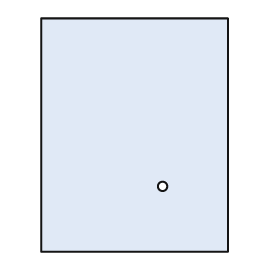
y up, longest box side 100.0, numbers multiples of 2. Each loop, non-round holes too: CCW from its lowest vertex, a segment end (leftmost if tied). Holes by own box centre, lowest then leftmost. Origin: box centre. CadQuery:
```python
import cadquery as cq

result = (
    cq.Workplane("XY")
    .moveTo(-40.0, -50.0)
    .lineTo(40.0, -50.0)
    .lineTo(40.0, 50.0)
    .lineTo(-40.0, 50.0)
    .close()
    .moveTo(12.0, -22.0)
    .circle(2.0)
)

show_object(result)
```